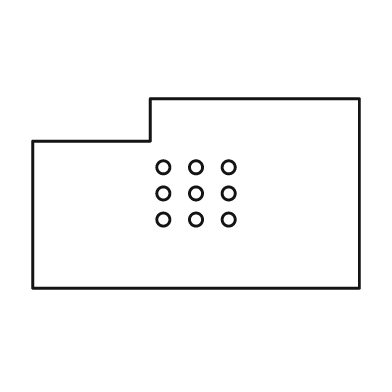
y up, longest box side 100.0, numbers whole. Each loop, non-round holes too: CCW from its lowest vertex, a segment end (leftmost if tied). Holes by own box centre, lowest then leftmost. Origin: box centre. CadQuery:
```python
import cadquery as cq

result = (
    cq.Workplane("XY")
    .moveTo(-50.0, -29.0)
    .lineTo(50.0, -29.0)
    .lineTo(50.0, 29.0)
    .lineTo(-14.0, 29.0)
    .lineTo(-14.0, 16.0)
    .lineTo(-50.0, 16.0)
    .close()
    .moveTo(-10.0, -8.0)
    .circle(2.0)
    .moveTo(0.0, -8.0)
    .circle(2.0)
    .moveTo(10.0, -8.0)
    .circle(2.0)
    .moveTo(-10.0, 0.0)
    .circle(2.0)
    .moveTo(0.0, 0.0)
    .circle(2.0)
    .moveTo(10.0, 0.0)
    .circle(2.0)
    .moveTo(-10.0, 8.0)
    .circle(2.0)
    .moveTo(0.0, 8.0)
    .circle(2.0)
    .moveTo(10.0, 8.0)
    .circle(2.0)
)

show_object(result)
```